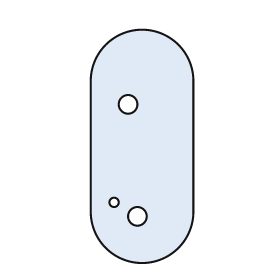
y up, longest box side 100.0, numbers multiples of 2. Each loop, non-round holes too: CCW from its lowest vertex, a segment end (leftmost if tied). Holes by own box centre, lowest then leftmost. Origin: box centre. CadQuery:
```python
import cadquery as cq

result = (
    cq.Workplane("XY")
    .moveTo(-22.0, -28.0)
    .threePointArc((0.0, -50.0), (22.0, -28.0))
    .lineTo(22.0, 28.0)
    .threePointArc((0.0, 50.0), (-22.0, 28.0))
    .close()
    .moveTo(-2.0, -30.0)
    .circle(4.0)
    .moveTo(-12.0, -24.0)
    .circle(2.0)
    .moveTo(-6.0, 18.0)
    .circle(4.0)
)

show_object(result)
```